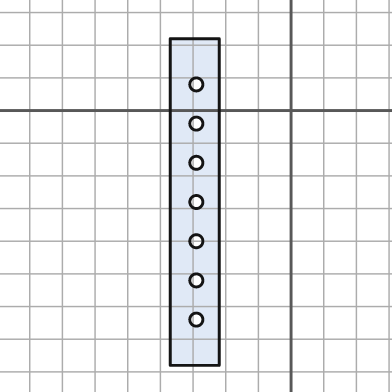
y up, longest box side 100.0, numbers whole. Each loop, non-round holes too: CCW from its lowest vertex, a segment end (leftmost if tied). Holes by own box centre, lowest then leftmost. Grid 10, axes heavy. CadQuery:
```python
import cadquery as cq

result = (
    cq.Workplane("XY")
    .moveTo(-37.0, -78.0)
    .lineTo(-22.0, -78.0)
    .lineTo(-22.0, 22.0)
    .lineTo(-37.0, 22.0)
    .close()
    .moveTo(-29.0, -64.0)
    .circle(2.0)
    .moveTo(-29.0, -52.0)
    .circle(2.0)
    .moveTo(-29.0, -40.0)
    .circle(2.0)
    .moveTo(-29.0, -28.0)
    .circle(2.0)
    .moveTo(-29.0, -16.0)
    .circle(2.0)
    .moveTo(-29.0, -4.0)
    .circle(2.0)
    .moveTo(-29.0, 8.0)
    .circle(2.0)
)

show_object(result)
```